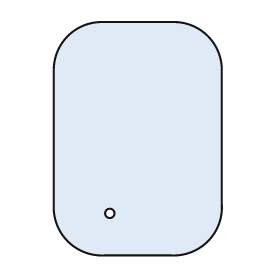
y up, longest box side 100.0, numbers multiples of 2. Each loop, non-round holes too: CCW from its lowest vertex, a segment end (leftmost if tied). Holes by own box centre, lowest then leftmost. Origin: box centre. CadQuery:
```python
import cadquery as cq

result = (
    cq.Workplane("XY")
    .moveTo(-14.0, -50.0)
    .lineTo(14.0, -50.0)
    .threePointArc((30.0, -44.0), (36.0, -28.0))
    .lineTo(36.0, 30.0)
    .threePointArc((30.0, 44.0), (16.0, 50.0))
    .lineTo(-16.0, 50.0)
    .threePointArc((-30.0, 44.0), (-36.0, 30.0))
    .lineTo(-36.0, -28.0)
    .threePointArc((-30.0, -44.0), (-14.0, -50.0))
    .close()
    .moveTo(-12.0, -32.0)
    .circle(2.0)
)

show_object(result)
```